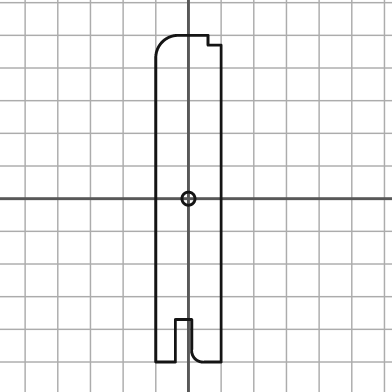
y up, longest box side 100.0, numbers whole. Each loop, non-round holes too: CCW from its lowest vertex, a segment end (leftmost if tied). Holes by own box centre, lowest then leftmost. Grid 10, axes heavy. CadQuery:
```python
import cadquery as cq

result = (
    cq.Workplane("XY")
    .moveTo(-10.0, -50.0)
    .lineTo(-4.0, -50.0)
    .lineTo(-4.0, -37.0)
    .lineTo(1.0, -37.0)
    .lineTo(1.0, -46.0)
    .threePointArc((2.0, -49.0), (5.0, -50.0))
    .lineTo(10.0, -50.0)
    .lineTo(10.0, 47.0)
    .lineTo(6.0, 47.0)
    .lineTo(6.0, 50.0)
    .lineTo(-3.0, 50.0)
    .threePointArc((-8.0, 48.0), (-10.0, 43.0))
    .close()
    .moveTo(0.0, 0.0)
    .circle(2.0)
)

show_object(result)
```